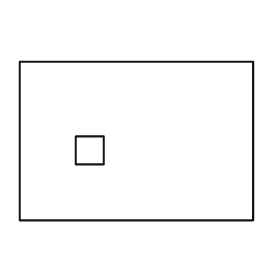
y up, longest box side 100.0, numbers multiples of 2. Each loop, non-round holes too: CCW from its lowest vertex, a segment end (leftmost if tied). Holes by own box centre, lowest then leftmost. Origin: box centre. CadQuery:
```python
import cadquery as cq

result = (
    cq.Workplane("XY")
    .moveTo(-50.0, -34.0)
    .lineTo(50.0, -34.0)
    .lineTo(50.0, 34.0)
    .lineTo(-50.0, 34.0)
    .close()
    .moveTo(-26.0, -10.0)
    .lineTo(-14.0, -10.0)
    .lineTo(-14.0, 2.0)
    .lineTo(-26.0, 2.0)
    .close()
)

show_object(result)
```